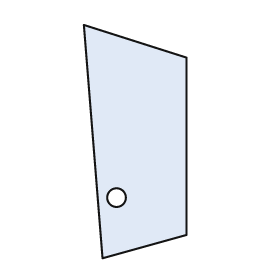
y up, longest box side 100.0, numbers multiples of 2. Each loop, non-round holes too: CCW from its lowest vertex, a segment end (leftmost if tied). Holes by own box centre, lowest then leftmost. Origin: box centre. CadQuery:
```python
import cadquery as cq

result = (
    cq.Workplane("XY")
    .moveTo(-14.0, -50.0)
    .lineTo(22.0, -40.0)
    .lineTo(22.0, 36.0)
    .lineTo(-22.0, 50.0)
    .close()
    .moveTo(-8.0, -24.0)
    .circle(4.0)
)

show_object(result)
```